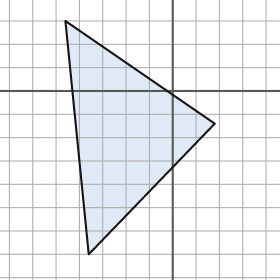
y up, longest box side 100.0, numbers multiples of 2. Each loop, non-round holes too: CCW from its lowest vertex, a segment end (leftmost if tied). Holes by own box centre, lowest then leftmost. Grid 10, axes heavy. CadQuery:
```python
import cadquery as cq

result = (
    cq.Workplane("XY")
    .moveTo(-36.0, -70.0)
    .lineTo(18.0, -14.0)
    .lineTo(-46.0, 30.0)
    .close()
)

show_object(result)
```